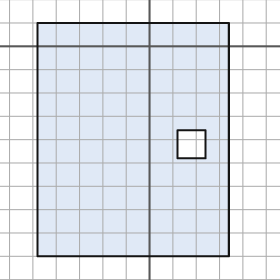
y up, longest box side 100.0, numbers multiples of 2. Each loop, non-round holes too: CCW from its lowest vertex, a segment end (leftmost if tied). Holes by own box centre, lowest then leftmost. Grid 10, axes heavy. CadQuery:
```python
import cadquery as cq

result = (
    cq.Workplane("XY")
    .moveTo(-48.0, -90.0)
    .lineTo(34.0, -90.0)
    .lineTo(34.0, 10.0)
    .lineTo(-48.0, 10.0)
    .close()
    .moveTo(12.0, -48.0)
    .lineTo(24.0, -48.0)
    .lineTo(24.0, -36.0)
    .lineTo(12.0, -36.0)
    .close()
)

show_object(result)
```